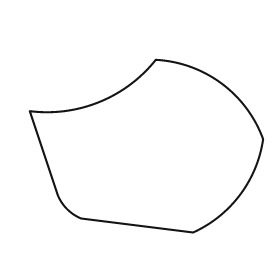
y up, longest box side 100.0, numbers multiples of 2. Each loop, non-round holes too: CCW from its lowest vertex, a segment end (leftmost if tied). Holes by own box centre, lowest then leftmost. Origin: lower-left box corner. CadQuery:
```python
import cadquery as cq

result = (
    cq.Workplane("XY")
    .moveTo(70.0, 0.0)
    .threePointArc((90.0, 16.0), (100.0, 40.0))
    .threePointArc((82.0, 64.0), (54.0, 74.0))
    .threePointArc((30.0, 56.0), (0.0, 52.0))
    .lineTo(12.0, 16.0)
    .threePointArc((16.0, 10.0), (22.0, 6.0))
    .close()
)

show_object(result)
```